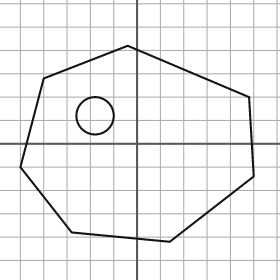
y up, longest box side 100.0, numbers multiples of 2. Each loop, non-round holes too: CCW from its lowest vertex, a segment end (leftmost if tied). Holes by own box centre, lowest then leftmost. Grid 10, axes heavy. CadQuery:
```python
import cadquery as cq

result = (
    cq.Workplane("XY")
    .moveTo(14.0, -42.0)
    .lineTo(50.0, -14.0)
    .lineTo(48.0, 20.0)
    .lineTo(-4.0, 42.0)
    .lineTo(-40.0, 28.0)
    .lineTo(-50.0, -10.0)
    .lineTo(-28.0, -38.0)
    .close()
    .moveTo(-18.0, 12.0)
    .circle(8.0)
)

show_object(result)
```